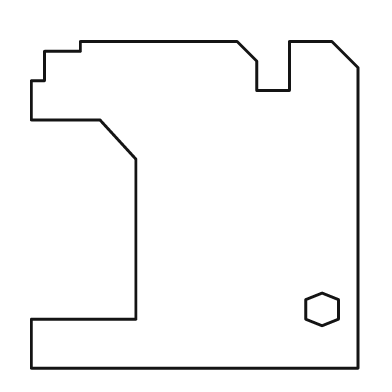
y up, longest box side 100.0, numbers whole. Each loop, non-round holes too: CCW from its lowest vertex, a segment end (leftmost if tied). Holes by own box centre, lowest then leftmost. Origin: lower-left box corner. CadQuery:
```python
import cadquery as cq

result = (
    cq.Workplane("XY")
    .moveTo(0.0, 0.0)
    .lineTo(100.0, 0.0)
    .lineTo(100.0, 92.0)
    .lineTo(92.0, 100.0)
    .lineTo(79.0, 100.0)
    .lineTo(79.0, 85.0)
    .lineTo(69.0, 85.0)
    .lineTo(69.0, 94.0)
    .lineTo(63.0, 100.0)
    .lineTo(15.0, 100.0)
    .lineTo(15.0, 97.0)
    .lineTo(4.0, 97.0)
    .lineTo(4.0, 88.0)
    .lineTo(0.0, 88.0)
    .lineTo(0.0, 76.0)
    .lineTo(21.0, 76.0)
    .lineTo(32.0, 64.0)
    .lineTo(32.0, 15.0)
    .lineTo(0.0, 15.0)
    .close()
    .moveTo(89.0, 13.0)
    .lineTo(94.0, 15.0)
    .lineTo(94.0, 21.0)
    .lineTo(89.0, 23.0)
    .lineTo(84.0, 21.0)
    .lineTo(84.0, 15.0)
    .close()
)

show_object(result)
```